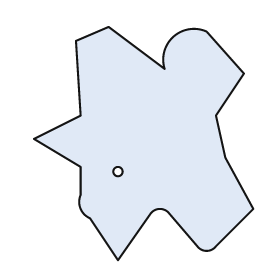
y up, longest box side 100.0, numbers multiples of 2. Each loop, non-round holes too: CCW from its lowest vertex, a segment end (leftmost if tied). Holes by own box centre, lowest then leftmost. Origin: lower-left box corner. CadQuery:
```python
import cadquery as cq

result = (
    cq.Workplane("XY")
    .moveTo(36.0, 0.0)
    .lineTo(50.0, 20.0)
    .threePointArc((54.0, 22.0), (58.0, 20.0))
    .lineTo(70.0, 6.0)
    .threePointArc((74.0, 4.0), (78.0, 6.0))
    .lineTo(94.0, 22.0)
    .lineTo(82.0, 44.0)
    .lineTo(78.0, 62.0)
    .lineTo(90.0, 80.0)
    .lineTo(74.0, 98.0)
    .threePointArc((60.0, 96.0), (56.0, 82.0))
    .lineTo(32.0, 100.0)
    .lineTo(18.0, 94.0)
    .lineTo(20.0, 62.0)
    .lineTo(0.0, 52.0)
    .lineTo(20.0, 40.0)
    .lineTo(20.0, 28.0)
    .threePointArc((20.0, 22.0), (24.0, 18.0))
    .close()
    .moveTo(36.0, 38.0)
    .circle(2.0)
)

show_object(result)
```